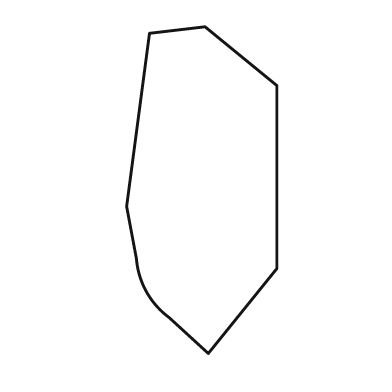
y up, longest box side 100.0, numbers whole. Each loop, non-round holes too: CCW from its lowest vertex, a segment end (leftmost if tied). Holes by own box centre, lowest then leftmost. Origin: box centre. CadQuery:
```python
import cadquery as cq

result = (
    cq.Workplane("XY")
    .moveTo(2.0, -50.0)
    .lineTo(23.0, -24.0)
    .lineTo(23.0, 32.0)
    .lineTo(1.0, 50.0)
    .lineTo(-16.0, 48.0)
    .lineTo(-23.0, -5.0)
    .lineTo(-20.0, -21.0)
    .threePointArc((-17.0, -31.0), (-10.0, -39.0))
    .close()
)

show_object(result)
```